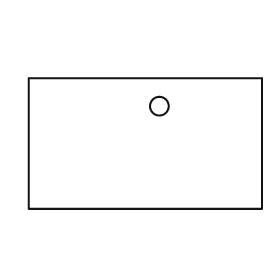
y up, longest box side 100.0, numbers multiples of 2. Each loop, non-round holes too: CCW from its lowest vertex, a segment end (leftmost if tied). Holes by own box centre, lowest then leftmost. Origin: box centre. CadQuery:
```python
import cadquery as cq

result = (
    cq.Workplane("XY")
    .moveTo(-50.0, -28.0)
    .lineTo(50.0, -28.0)
    .lineTo(50.0, 28.0)
    .lineTo(-50.0, 28.0)
    .close()
    .moveTo(6.0, 16.0)
    .circle(4.0)
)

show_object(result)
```